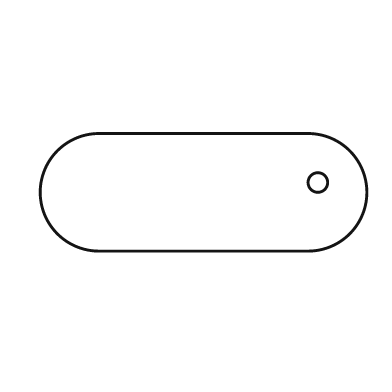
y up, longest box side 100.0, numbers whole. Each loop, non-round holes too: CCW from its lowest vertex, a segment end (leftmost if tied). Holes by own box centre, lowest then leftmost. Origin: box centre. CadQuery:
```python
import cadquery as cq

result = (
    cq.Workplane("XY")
    .moveTo(-32.0, -18.0)
    .lineTo(32.0, -18.0)
    .threePointArc((50.0, 0.0), (32.0, 18.0))
    .lineTo(-32.0, 18.0)
    .threePointArc((-50.0, 0.0), (-32.0, -18.0))
    .close()
    .moveTo(35.0, 3.0)
    .circle(3.0)
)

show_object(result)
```